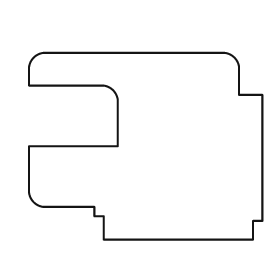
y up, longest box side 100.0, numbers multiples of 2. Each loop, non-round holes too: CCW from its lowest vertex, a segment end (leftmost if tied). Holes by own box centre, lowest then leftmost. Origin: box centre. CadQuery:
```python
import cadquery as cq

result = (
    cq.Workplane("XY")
    .moveTo(-18.0, -40.0)
    .lineTo(46.0, -40.0)
    .lineTo(46.0, -32.0)
    .lineTo(50.0, -32.0)
    .lineTo(50.0, 22.0)
    .lineTo(40.0, 22.0)
    .lineTo(40.0, 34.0)
    .threePointArc((38.0, 38.0), (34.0, 40.0))
    .lineTo(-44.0, 40.0)
    .threePointArc((-48.0, 38.0), (-50.0, 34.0))
    .lineTo(-50.0, 26.0)
    .lineTo(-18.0, 26.0)
    .threePointArc((-14.0, 24.0), (-12.0, 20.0))
    .lineTo(-12.0, 0.0)
    .lineTo(-50.0, 0.0)
    .lineTo(-50.0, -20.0)
    .threePointArc((-48.0, -24.0), (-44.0, -26.0))
    .lineTo(-22.0, -26.0)
    .lineTo(-22.0, -30.0)
    .lineTo(-18.0, -30.0)
    .close()
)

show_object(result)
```